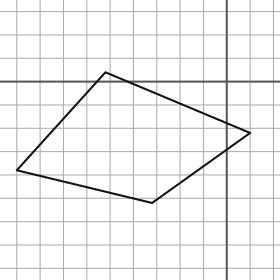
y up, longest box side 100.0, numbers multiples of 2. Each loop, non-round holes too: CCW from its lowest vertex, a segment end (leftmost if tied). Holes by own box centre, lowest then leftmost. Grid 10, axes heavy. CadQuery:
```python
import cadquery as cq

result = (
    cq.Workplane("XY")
    .moveTo(-32.0, -52.0)
    .lineTo(10.0, -22.0)
    .lineTo(-52.0, 4.0)
    .lineTo(-90.0, -38.0)
    .close()
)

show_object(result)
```